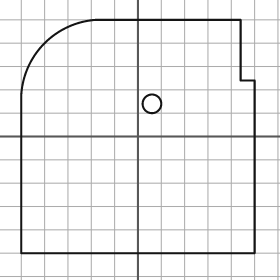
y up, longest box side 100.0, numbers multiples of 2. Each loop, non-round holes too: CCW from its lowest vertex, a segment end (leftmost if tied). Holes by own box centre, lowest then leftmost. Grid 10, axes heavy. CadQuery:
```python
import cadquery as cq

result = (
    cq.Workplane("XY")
    .moveTo(-50.0, -50.0)
    .lineTo(50.0, -50.0)
    .lineTo(50.0, 24.0)
    .lineTo(44.0, 24.0)
    .lineTo(44.0, 50.0)
    .lineTo(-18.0, 50.0)
    .threePointArc((-40.0, 40.0), (-50.0, 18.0))
    .close()
    .moveTo(6.0, 14.0)
    .circle(4.0)
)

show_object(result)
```